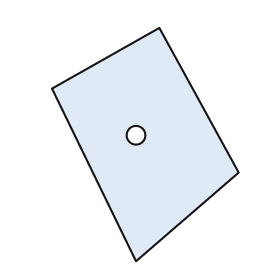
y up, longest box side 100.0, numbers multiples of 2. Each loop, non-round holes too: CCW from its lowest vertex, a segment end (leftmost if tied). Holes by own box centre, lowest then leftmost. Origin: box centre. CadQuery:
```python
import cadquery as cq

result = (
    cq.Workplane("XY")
    .moveTo(-4.0, -50.0)
    .lineTo(40.0, -12.0)
    .lineTo(6.0, 50.0)
    .lineTo(-40.0, 24.0)
    .close()
    .moveTo(-4.0, 4.0)
    .circle(4.0)
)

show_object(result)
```